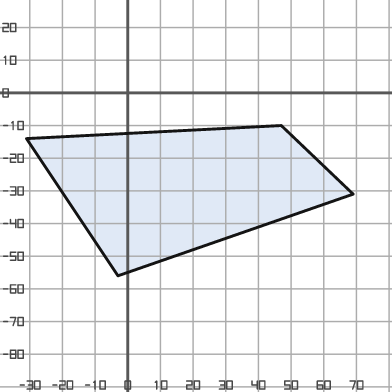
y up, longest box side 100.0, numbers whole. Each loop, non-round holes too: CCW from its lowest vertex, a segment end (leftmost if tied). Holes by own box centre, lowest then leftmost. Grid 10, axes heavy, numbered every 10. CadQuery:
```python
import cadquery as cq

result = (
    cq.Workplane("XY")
    .moveTo(-3.0, -56.0)
    .lineTo(69.0, -31.0)
    .lineTo(47.0, -10.0)
    .lineTo(-31.0, -14.0)
    .close()
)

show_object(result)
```